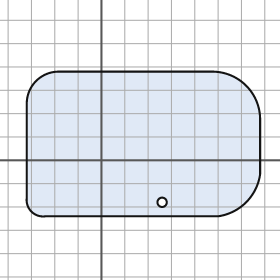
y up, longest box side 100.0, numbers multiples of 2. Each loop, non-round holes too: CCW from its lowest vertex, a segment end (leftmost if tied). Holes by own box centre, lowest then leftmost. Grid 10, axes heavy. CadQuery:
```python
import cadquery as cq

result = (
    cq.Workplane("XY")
    .moveTo(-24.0, -24.0)
    .lineTo(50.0, -24.0)
    .threePointArc((62.0, -18.0), (68.0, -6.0))
    .lineTo(68.0, 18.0)
    .threePointArc((62.0, 32.0), (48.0, 38.0))
    .lineTo(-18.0, 38.0)
    .threePointArc((-28.0, 34.0), (-32.0, 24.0))
    .lineTo(-32.0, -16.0)
    .threePointArc((-30.0, -22.0), (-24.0, -24.0))
    .close()
    .moveTo(26.0, -18.0)
    .circle(2.0)
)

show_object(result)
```